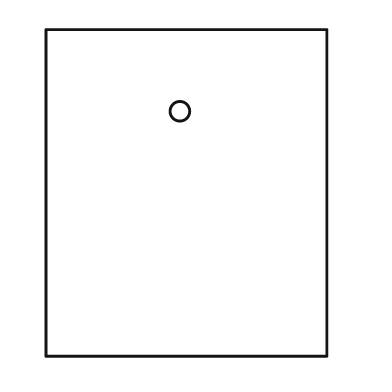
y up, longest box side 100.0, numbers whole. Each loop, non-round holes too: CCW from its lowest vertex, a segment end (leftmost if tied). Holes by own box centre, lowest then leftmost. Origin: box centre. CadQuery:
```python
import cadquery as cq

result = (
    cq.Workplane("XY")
    .moveTo(-43.0, -50.0)
    .lineTo(43.0, -50.0)
    .lineTo(43.0, 50.0)
    .lineTo(-43.0, 50.0)
    .close()
    .moveTo(-2.0, 25.0)
    .circle(3.0)
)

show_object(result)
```